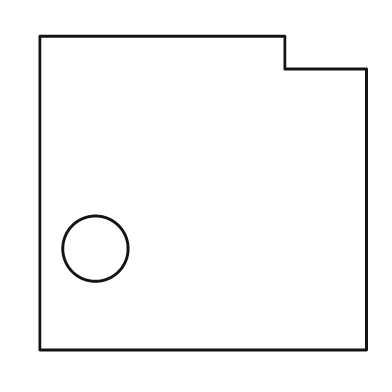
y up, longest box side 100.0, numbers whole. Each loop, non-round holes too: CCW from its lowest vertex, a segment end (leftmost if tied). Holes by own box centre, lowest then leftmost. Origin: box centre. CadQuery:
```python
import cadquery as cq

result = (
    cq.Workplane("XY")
    .moveTo(-50.0, -48.0)
    .lineTo(50.0, -48.0)
    .lineTo(50.0, 38.0)
    .lineTo(25.0, 38.0)
    .lineTo(25.0, 48.0)
    .lineTo(-50.0, 48.0)
    .close()
    .moveTo(-33.0, -17.0)
    .circle(10.0)
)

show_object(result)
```